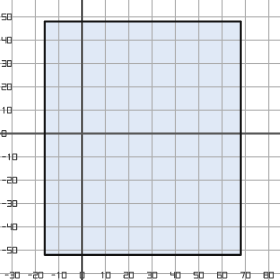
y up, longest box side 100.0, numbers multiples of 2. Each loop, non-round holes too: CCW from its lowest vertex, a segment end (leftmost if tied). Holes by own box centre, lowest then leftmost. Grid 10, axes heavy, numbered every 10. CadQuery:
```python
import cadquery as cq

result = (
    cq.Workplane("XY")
    .moveTo(-16.0, -52.0)
    .lineTo(68.0, -52.0)
    .lineTo(68.0, 48.0)
    .lineTo(-16.0, 48.0)
    .close()
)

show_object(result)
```